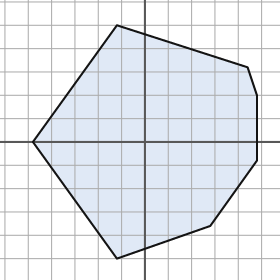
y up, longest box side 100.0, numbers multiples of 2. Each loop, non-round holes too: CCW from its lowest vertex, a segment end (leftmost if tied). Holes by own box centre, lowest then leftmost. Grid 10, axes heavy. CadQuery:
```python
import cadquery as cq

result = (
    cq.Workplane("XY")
    .moveTo(-12.0, -50.0)
    .lineTo(28.0, -36.0)
    .lineTo(48.0, -8.0)
    .lineTo(48.0, 20.0)
    .lineTo(44.0, 32.0)
    .lineTo(-12.0, 50.0)
    .lineTo(-48.0, 0.0)
    .close()
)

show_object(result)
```